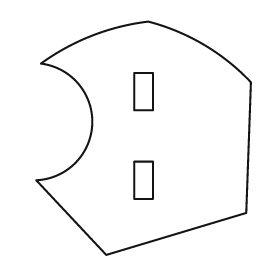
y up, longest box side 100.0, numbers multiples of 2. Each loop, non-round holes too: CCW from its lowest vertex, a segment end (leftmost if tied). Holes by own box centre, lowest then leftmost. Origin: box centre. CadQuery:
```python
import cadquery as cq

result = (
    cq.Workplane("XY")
    .moveTo(-16.0, -50.0)
    .lineTo(44.0, -32.0)
    .lineTo(46.0, 24.0)
    .threePointArc((26.0, 40.0), (2.0, 50.0))
    .threePointArc((-22.0, 44.0), (-44.0, 32.0))
    .threePointArc((-22.0, 6.0), (-46.0, -18.0))
    .close()
    .moveTo(-4.0, -26.0)
    .lineTo(4.0, -26.0)
    .lineTo(4.0, -10.0)
    .lineTo(-4.0, -10.0)
    .close()
    .moveTo(-4.0, 12.0)
    .lineTo(4.0, 12.0)
    .lineTo(4.0, 28.0)
    .lineTo(-4.0, 28.0)
    .close()
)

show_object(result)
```